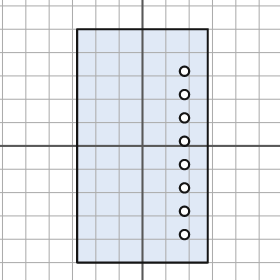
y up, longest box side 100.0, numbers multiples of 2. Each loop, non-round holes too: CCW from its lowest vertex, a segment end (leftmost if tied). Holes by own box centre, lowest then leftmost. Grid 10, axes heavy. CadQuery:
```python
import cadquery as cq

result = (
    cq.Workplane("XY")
    .moveTo(-28.0, -50.0)
    .lineTo(28.0, -50.0)
    .lineTo(28.0, 50.0)
    .lineTo(-28.0, 50.0)
    .close()
    .moveTo(18.0, -38.0)
    .circle(2.0)
    .moveTo(18.0, -28.0)
    .circle(2.0)
    .moveTo(18.0, -18.0)
    .circle(2.0)
    .moveTo(18.0, -8.0)
    .circle(2.0)
    .moveTo(18.0, 2.0)
    .circle(2.0)
    .moveTo(18.0, 12.0)
    .circle(2.0)
    .moveTo(18.0, 22.0)
    .circle(2.0)
    .moveTo(18.0, 32.0)
    .circle(2.0)
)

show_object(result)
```